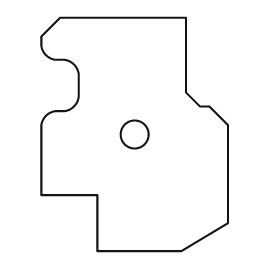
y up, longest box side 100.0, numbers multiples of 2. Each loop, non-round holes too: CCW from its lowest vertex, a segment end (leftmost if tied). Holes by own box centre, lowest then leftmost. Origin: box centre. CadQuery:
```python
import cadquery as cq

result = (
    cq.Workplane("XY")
    .moveTo(-16.0, -50.0)
    .lineTo(20.0, -50.0)
    .lineTo(40.0, -38.0)
    .lineTo(40.0, 4.0)
    .lineTo(32.0, 12.0)
    .lineTo(28.0, 12.0)
    .lineTo(22.0, 18.0)
    .lineTo(22.0, 50.0)
    .lineTo(-32.0, 50.0)
    .lineTo(-40.0, 42.0)
    .lineTo(-40.0, 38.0)
    .threePointArc((-38.0, 34.0), (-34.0, 32.0))
    .lineTo(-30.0, 32.0)
    .threePointArc((-26.0, 30.0), (-24.0, 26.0))
    .lineTo(-24.0, 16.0)
    .threePointArc((-26.0, 12.0), (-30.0, 10.0))
    .lineTo(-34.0, 10.0)
    .threePointArc((-38.0, 8.0), (-40.0, 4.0))
    .lineTo(-40.0, -26.0)
    .lineTo(-16.0, -26.0)
    .close()
    .moveTo(0.0, 0.0)
    .circle(6.0)
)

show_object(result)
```